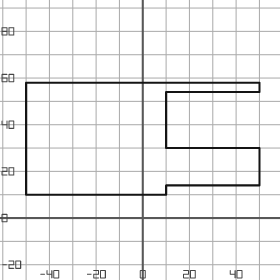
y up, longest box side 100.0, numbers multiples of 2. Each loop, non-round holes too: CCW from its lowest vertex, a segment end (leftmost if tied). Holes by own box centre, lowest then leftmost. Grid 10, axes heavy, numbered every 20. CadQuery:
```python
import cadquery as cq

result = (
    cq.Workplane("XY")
    .moveTo(-50.0, 10.0)
    .lineTo(10.0, 10.0)
    .lineTo(10.0, 14.0)
    .lineTo(50.0, 14.0)
    .lineTo(50.0, 30.0)
    .lineTo(10.0, 30.0)
    .lineTo(10.0, 54.0)
    .lineTo(50.0, 54.0)
    .lineTo(50.0, 58.0)
    .lineTo(-50.0, 58.0)
    .close()
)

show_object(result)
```